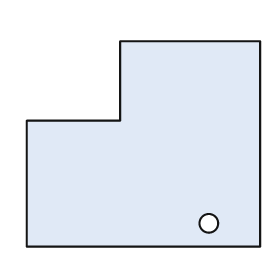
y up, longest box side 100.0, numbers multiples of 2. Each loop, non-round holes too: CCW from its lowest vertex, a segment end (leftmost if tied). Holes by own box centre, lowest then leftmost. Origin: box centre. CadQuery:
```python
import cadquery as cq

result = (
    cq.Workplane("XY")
    .moveTo(-50.0, -44.0)
    .lineTo(50.0, -44.0)
    .lineTo(50.0, 44.0)
    .lineTo(-10.0, 44.0)
    .lineTo(-10.0, 10.0)
    .lineTo(-50.0, 10.0)
    .close()
    .moveTo(28.0, -34.0)
    .circle(4.0)
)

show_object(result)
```